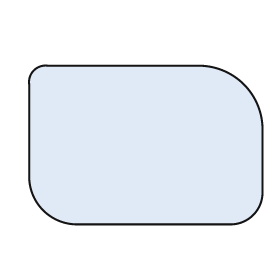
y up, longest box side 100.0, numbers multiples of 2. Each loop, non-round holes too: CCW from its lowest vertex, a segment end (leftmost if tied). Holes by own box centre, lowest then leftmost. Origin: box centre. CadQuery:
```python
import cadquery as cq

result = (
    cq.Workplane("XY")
    .moveTo(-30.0, -34.0)
    .lineTo(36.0, -34.0)
    .threePointArc((46.0, -30.0), (50.0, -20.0))
    .lineTo(50.0, 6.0)
    .threePointArc((42.0, 26.0), (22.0, 34.0))
    .lineTo(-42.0, 34.0)
    .threePointArc((-48.0, 32.0), (-50.0, 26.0))
    .lineTo(-50.0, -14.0)
    .threePointArc((-44.0, -28.0), (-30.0, -34.0))
    .close()
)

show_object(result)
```